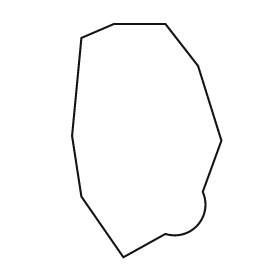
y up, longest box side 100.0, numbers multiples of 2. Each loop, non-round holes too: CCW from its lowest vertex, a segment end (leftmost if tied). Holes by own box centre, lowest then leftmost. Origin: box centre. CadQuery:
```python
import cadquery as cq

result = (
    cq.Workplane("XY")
    .moveTo(-10.0, -50.0)
    .lineTo(8.0, -40.0)
    .threePointArc((22.0, -36.0), (24.0, -22.0))
    .lineTo(32.0, 0.0)
    .lineTo(22.0, 32.0)
    .lineTo(8.0, 50.0)
    .lineTo(-14.0, 50.0)
    .lineTo(-28.0, 44.0)
    .lineTo(-32.0, 2.0)
    .lineTo(-28.0, -24.0)
    .close()
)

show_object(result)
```